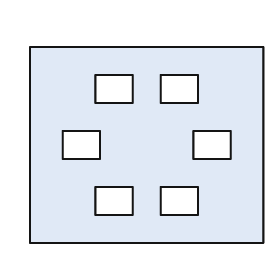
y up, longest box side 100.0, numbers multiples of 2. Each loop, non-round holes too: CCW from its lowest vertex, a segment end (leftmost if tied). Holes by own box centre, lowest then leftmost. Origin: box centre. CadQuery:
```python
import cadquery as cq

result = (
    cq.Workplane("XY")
    .moveTo(-50.0, -42.0)
    .lineTo(50.0, -42.0)
    .lineTo(50.0, 42.0)
    .lineTo(-50.0, 42.0)
    .close()
    .moveTo(-22.0, -30.0)
    .lineTo(-6.0, -30.0)
    .lineTo(-6.0, -18.0)
    .lineTo(-22.0, -18.0)
    .close()
    .moveTo(6.0, -30.0)
    .lineTo(22.0, -30.0)
    .lineTo(22.0, -18.0)
    .lineTo(6.0, -18.0)
    .close()
    .moveTo(-36.0, -6.0)
    .lineTo(-20.0, -6.0)
    .lineTo(-20.0, 6.0)
    .lineTo(-36.0, 6.0)
    .close()
    .moveTo(20.0, -6.0)
    .lineTo(36.0, -6.0)
    .lineTo(36.0, 6.0)
    .lineTo(20.0, 6.0)
    .close()
    .moveTo(-22.0, 18.0)
    .lineTo(-6.0, 18.0)
    .lineTo(-6.0, 30.0)
    .lineTo(-22.0, 30.0)
    .close()
    .moveTo(6.0, 18.0)
    .lineTo(22.0, 18.0)
    .lineTo(22.0, 30.0)
    .lineTo(6.0, 30.0)
    .close()
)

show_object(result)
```